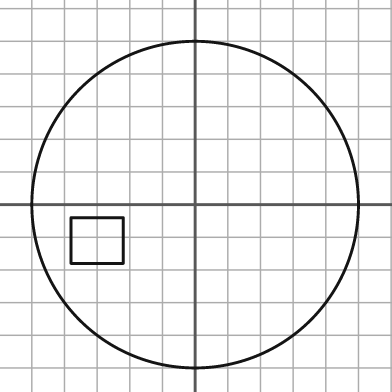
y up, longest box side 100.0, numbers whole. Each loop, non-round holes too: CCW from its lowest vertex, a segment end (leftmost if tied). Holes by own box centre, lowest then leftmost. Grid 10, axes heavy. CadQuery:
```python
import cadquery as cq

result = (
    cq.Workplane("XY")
    .moveTo(0.0, 0.0)
    .circle(50.0)
    .moveTo(-38.0, -18.0)
    .lineTo(-22.0, -18.0)
    .lineTo(-22.0, -4.0)
    .lineTo(-38.0, -4.0)
    .close()
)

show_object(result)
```